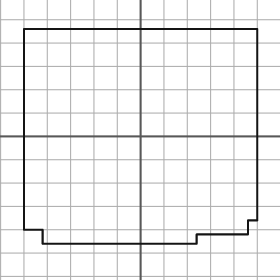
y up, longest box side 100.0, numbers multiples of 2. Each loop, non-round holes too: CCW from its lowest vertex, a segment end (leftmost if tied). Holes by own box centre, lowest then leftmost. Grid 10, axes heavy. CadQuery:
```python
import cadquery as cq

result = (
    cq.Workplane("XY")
    .moveTo(-42.0, -46.0)
    .lineTo(24.0, -46.0)
    .lineTo(24.0, -42.0)
    .lineTo(46.0, -42.0)
    .lineTo(46.0, -36.0)
    .lineTo(50.0, -36.0)
    .lineTo(50.0, 46.0)
    .lineTo(-50.0, 46.0)
    .lineTo(-50.0, -40.0)
    .lineTo(-42.0, -40.0)
    .close()
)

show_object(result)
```